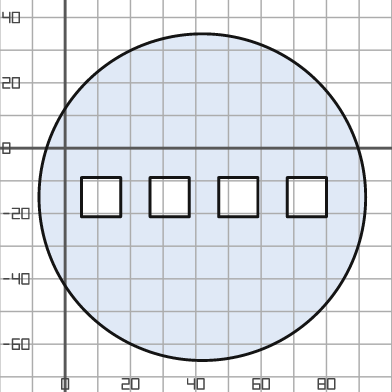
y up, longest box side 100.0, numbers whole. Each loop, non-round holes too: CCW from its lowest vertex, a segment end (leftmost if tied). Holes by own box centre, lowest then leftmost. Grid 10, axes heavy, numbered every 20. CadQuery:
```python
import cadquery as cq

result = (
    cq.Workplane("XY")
    .moveTo(42.0, -15.0)
    .circle(50.0)
    .moveTo(5.0, -21.0)
    .lineTo(17.0, -21.0)
    .lineTo(17.0, -9.0)
    .lineTo(5.0, -9.0)
    .close()
    .moveTo(26.0, -21.0)
    .lineTo(38.0, -21.0)
    .lineTo(38.0, -9.0)
    .lineTo(26.0, -9.0)
    .close()
    .moveTo(47.0, -21.0)
    .lineTo(59.0, -21.0)
    .lineTo(59.0, -9.0)
    .lineTo(47.0, -9.0)
    .close()
    .moveTo(68.0, -21.0)
    .lineTo(80.0, -21.0)
    .lineTo(80.0, -9.0)
    .lineTo(68.0, -9.0)
    .close()
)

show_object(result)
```